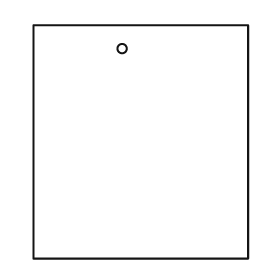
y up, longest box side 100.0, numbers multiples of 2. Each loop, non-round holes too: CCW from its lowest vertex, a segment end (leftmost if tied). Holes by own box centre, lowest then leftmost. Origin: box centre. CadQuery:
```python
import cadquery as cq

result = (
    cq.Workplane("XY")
    .moveTo(-46.0, -50.0)
    .lineTo(46.0, -50.0)
    .lineTo(46.0, 50.0)
    .lineTo(-46.0, 50.0)
    .close()
    .moveTo(-8.0, 40.0)
    .circle(2.0)
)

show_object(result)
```